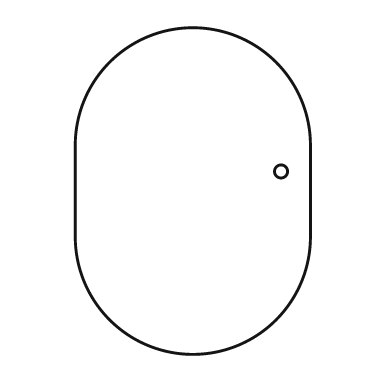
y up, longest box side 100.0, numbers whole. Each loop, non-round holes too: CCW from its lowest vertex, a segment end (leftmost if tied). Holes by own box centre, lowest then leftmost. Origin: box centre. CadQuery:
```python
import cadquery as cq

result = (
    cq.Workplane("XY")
    .moveTo(-36.0, -14.0)
    .threePointArc((0.0, -50.0), (36.0, -14.0))
    .lineTo(36.0, 14.0)
    .threePointArc((0.0, 50.0), (-36.0, 14.0))
    .close()
    .moveTo(27.0, 6.0)
    .circle(2.0)
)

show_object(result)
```